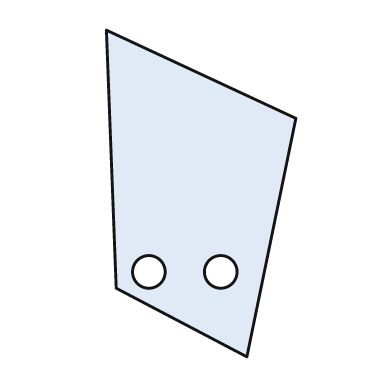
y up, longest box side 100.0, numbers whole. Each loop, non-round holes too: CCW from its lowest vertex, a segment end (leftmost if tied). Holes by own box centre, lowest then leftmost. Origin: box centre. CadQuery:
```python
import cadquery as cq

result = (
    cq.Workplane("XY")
    .moveTo(14.0, -50.0)
    .lineTo(29.0, 23.0)
    .lineTo(-29.0, 50.0)
    .lineTo(-26.0, -29.0)
    .close()
    .moveTo(-16.0, -24.0)
    .circle(5.0)
    .moveTo(6.0, -24.0)
    .circle(5.0)
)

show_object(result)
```